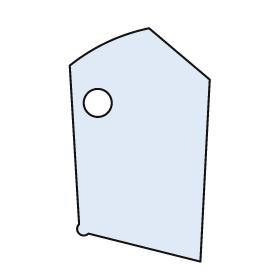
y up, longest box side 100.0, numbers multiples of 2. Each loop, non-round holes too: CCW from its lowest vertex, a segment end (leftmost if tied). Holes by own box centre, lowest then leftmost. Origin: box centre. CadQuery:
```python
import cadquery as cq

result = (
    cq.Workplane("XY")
    .moveTo(26.0, -50.0)
    .lineTo(30.0, 28.0)
    .lineTo(4.0, 50.0)
    .threePointArc((-14.0, 44.0), (-30.0, 34.0))
    .lineTo(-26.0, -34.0)
    .threePointArc((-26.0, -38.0), (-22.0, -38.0))
    .close()
    .moveTo(-18.0, 18.0)
    .circle(6.0)
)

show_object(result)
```